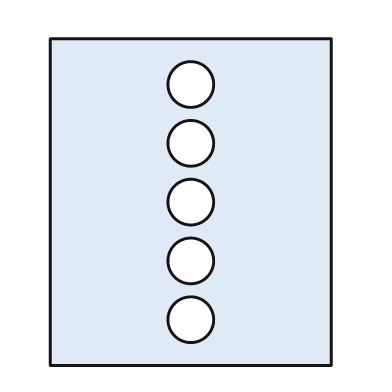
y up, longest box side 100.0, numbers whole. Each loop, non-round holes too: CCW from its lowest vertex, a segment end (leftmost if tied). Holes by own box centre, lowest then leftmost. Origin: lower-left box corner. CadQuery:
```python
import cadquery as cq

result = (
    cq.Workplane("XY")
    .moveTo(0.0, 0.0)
    .lineTo(86.0, 0.0)
    .lineTo(86.0, 100.0)
    .lineTo(0.0, 100.0)
    .close()
    .moveTo(43.0, 14.0)
    .circle(7.0)
    .moveTo(43.0, 32.0)
    .circle(7.0)
    .moveTo(43.0, 50.0)
    .circle(7.0)
    .moveTo(43.0, 68.0)
    .circle(7.0)
    .moveTo(43.0, 86.0)
    .circle(7.0)
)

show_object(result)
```